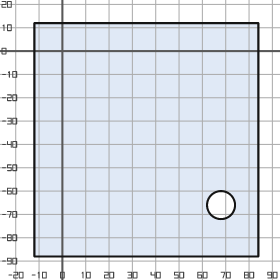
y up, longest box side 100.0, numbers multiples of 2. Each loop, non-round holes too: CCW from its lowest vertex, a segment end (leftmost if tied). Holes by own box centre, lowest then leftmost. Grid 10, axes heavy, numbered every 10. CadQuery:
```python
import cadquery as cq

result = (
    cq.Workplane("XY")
    .moveTo(-12.0, -88.0)
    .lineTo(84.0, -88.0)
    .lineTo(84.0, 12.0)
    .lineTo(-12.0, 12.0)
    .close()
    .moveTo(68.0, -66.0)
    .circle(6.0)
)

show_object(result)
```